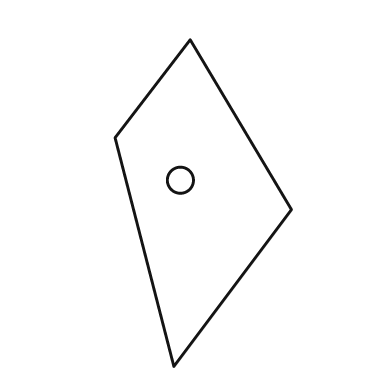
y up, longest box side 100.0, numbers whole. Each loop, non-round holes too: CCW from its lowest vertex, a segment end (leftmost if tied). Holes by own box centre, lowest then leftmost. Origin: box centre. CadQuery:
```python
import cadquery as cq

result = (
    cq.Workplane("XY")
    .moveTo(-9.0, -50.0)
    .lineTo(27.0, -2.0)
    .lineTo(-4.0, 50.0)
    .lineTo(-27.0, 20.0)
    .close()
    .moveTo(-7.0, 7.0)
    .circle(4.0)
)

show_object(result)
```